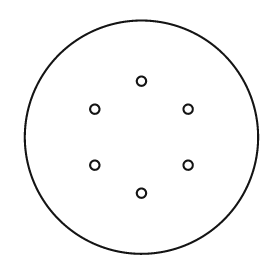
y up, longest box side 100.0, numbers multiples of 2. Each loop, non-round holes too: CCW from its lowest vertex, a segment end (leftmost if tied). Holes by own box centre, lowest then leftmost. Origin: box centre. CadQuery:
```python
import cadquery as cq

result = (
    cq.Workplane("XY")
    .moveTo(0.0, 0.0)
    .circle(50.0)
    .moveTo(0.0, -24.0)
    .circle(2.0)
    .moveTo(-20.0, -12.0)
    .circle(2.0)
    .moveTo(20.0, -12.0)
    .circle(2.0)
    .moveTo(-20.0, 12.0)
    .circle(2.0)
    .moveTo(20.0, 12.0)
    .circle(2.0)
    .moveTo(0.0, 24.0)
    .circle(2.0)
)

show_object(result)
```